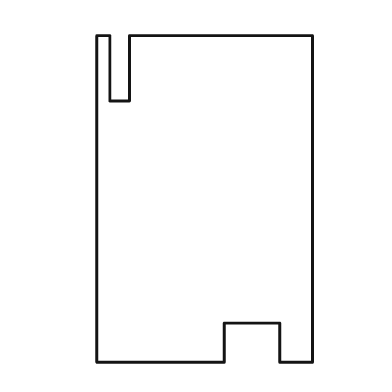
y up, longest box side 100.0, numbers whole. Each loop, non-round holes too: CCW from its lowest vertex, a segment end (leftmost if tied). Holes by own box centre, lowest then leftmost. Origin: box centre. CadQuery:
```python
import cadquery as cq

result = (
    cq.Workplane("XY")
    .moveTo(-33.0, -50.0)
    .lineTo(6.0, -50.0)
    .lineTo(6.0, -38.0)
    .lineTo(23.0, -38.0)
    .lineTo(23.0, -50.0)
    .lineTo(33.0, -50.0)
    .lineTo(33.0, 50.0)
    .lineTo(-23.0, 50.0)
    .lineTo(-23.0, 30.0)
    .lineTo(-29.0, 30.0)
    .lineTo(-29.0, 50.0)
    .lineTo(-33.0, 50.0)
    .close()
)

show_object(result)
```